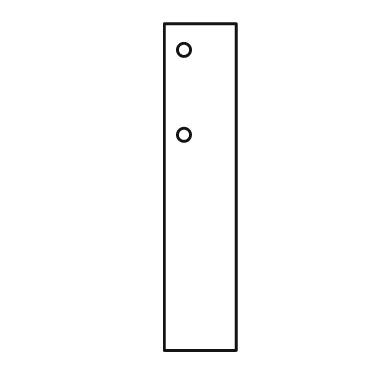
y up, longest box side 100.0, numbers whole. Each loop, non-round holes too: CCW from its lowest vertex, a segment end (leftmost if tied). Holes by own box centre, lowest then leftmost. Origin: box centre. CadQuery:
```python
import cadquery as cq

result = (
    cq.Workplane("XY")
    .moveTo(-11.0, -50.0)
    .lineTo(11.0, -50.0)
    .lineTo(11.0, 50.0)
    .lineTo(-11.0, 50.0)
    .close()
    .moveTo(-5.0, 16.0)
    .circle(2.0)
    .moveTo(-5.0, 42.0)
    .circle(2.0)
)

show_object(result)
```